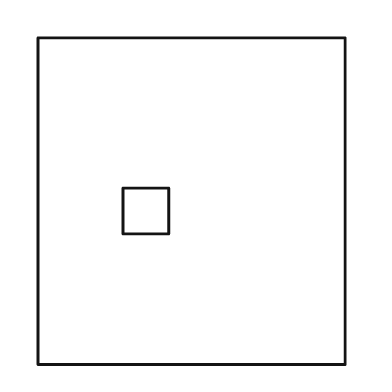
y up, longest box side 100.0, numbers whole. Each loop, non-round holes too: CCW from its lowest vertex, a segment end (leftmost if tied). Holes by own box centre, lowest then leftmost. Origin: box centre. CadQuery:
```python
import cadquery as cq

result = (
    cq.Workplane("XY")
    .moveTo(-47.0, -50.0)
    .lineTo(47.0, -50.0)
    .lineTo(47.0, 50.0)
    .lineTo(-47.0, 50.0)
    .close()
    .moveTo(-21.0, -10.0)
    .lineTo(-7.0, -10.0)
    .lineTo(-7.0, 4.0)
    .lineTo(-21.0, 4.0)
    .close()
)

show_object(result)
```